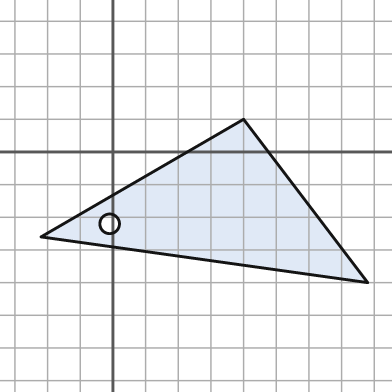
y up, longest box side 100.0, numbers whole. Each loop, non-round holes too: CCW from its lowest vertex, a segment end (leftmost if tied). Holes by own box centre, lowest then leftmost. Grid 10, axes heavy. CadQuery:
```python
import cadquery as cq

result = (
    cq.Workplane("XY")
    .moveTo(78.0, -40.0)
    .lineTo(40.0, 10.0)
    .lineTo(-22.0, -26.0)
    .close()
    .moveTo(-1.0, -22.0)
    .circle(3.0)
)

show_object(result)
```